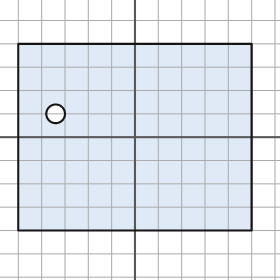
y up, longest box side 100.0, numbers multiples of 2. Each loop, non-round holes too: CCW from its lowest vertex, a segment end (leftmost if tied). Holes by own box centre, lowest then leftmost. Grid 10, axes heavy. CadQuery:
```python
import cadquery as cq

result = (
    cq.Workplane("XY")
    .moveTo(-50.0, -40.0)
    .lineTo(50.0, -40.0)
    .lineTo(50.0, 40.0)
    .lineTo(-50.0, 40.0)
    .close()
    .moveTo(-34.0, 10.0)
    .circle(4.0)
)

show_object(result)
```